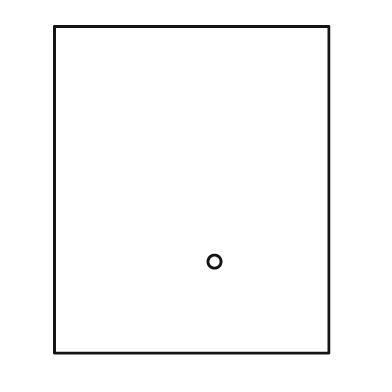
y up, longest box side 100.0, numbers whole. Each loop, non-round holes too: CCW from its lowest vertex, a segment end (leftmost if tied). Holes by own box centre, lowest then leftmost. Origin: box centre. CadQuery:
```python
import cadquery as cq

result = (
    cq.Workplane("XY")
    .moveTo(-42.0, -50.0)
    .lineTo(42.0, -50.0)
    .lineTo(42.0, 50.0)
    .lineTo(-42.0, 50.0)
    .close()
    .moveTo(7.0, -22.0)
    .circle(2.0)
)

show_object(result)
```